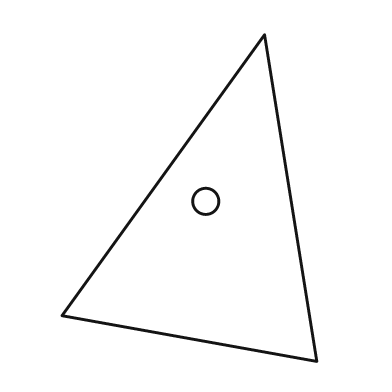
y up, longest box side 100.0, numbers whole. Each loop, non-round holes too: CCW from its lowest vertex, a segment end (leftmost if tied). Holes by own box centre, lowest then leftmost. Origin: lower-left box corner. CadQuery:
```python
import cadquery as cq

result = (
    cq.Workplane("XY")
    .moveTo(78.0, 0.0)
    .lineTo(62.0, 100.0)
    .lineTo(0.0, 14.0)
    .close()
    .moveTo(44.0, 49.0)
    .circle(4.0)
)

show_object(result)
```